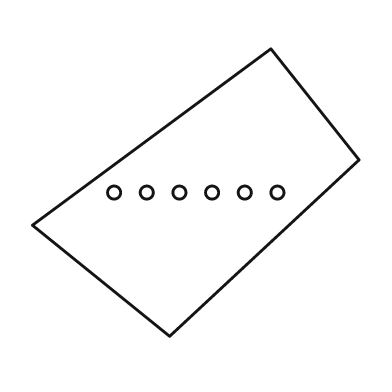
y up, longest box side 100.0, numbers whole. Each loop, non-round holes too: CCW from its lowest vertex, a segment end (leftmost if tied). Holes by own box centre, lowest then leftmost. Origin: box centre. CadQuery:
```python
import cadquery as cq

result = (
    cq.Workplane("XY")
    .moveTo(-8.0, -44.0)
    .lineTo(50.0, 10.0)
    .lineTo(23.0, 44.0)
    .lineTo(-50.0, -10.0)
    .close()
    .moveTo(-25.0, 0.0)
    .circle(2.0)
    .moveTo(-15.0, 0.0)
    .circle(2.0)
    .moveTo(-5.0, 0.0)
    .circle(2.0)
    .moveTo(5.0, 0.0)
    .circle(2.0)
    .moveTo(15.0, 0.0)
    .circle(2.0)
    .moveTo(25.0, 0.0)
    .circle(2.0)
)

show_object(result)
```